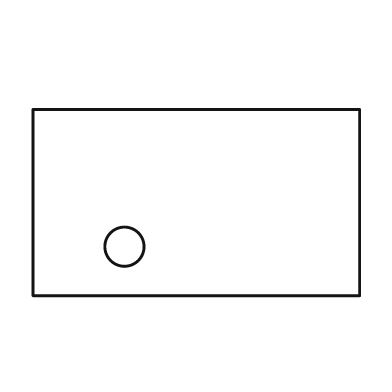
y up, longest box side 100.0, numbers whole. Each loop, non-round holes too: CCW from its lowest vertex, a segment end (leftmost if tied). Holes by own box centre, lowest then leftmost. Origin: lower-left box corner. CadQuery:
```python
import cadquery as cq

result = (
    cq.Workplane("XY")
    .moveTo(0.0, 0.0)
    .lineTo(100.0, 0.0)
    .lineTo(100.0, 57.0)
    .lineTo(0.0, 57.0)
    .close()
    .moveTo(28.0, 15.0)
    .circle(6.0)
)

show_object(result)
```